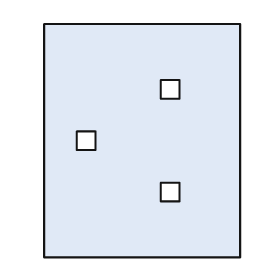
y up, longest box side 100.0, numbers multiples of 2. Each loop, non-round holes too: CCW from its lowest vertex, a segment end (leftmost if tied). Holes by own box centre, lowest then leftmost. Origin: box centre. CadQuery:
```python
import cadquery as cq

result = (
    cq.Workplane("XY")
    .moveTo(-42.0, -50.0)
    .lineTo(42.0, -50.0)
    .lineTo(42.0, 50.0)
    .lineTo(-42.0, 50.0)
    .close()
    .moveTo(8.0, -26.0)
    .lineTo(16.0, -26.0)
    .lineTo(16.0, -18.0)
    .lineTo(8.0, -18.0)
    .close()
    .moveTo(-28.0, -4.0)
    .lineTo(-20.0, -4.0)
    .lineTo(-20.0, 4.0)
    .lineTo(-28.0, 4.0)
    .close()
    .moveTo(8.0, 18.0)
    .lineTo(16.0, 18.0)
    .lineTo(16.0, 26.0)
    .lineTo(8.0, 26.0)
    .close()
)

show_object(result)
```